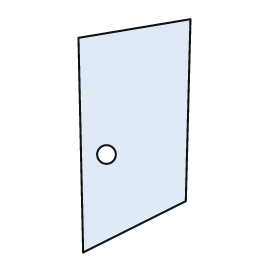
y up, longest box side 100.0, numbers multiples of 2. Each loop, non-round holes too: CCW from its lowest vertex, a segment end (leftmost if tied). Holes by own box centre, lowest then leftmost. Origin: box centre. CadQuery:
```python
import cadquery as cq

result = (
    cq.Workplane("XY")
    .moveTo(-22.0, -50.0)
    .lineTo(22.0, -28.0)
    .lineTo(24.0, 50.0)
    .lineTo(-24.0, 42.0)
    .close()
    .moveTo(-12.0, -8.0)
    .circle(4.0)
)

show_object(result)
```